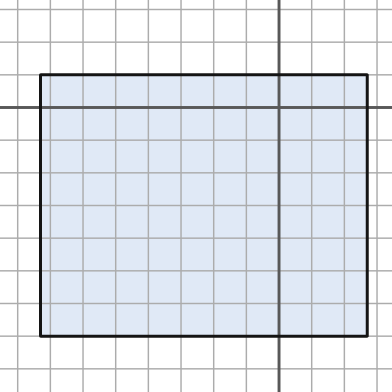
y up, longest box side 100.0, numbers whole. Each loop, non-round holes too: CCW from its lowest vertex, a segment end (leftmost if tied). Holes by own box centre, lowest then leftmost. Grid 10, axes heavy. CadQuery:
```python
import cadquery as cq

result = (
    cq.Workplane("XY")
    .moveTo(-73.0, -70.0)
    .lineTo(27.0, -70.0)
    .lineTo(27.0, 10.0)
    .lineTo(-73.0, 10.0)
    .close()
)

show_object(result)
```